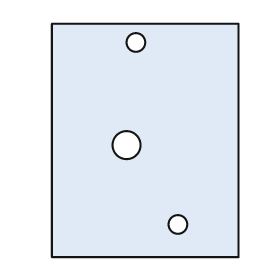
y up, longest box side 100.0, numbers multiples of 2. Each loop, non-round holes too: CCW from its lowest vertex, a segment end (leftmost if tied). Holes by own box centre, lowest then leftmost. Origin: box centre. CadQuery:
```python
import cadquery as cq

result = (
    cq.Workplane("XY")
    .moveTo(-40.0, -50.0)
    .lineTo(40.0, -50.0)
    .lineTo(40.0, 50.0)
    .lineTo(-40.0, 50.0)
    .close()
    .moveTo(14.0, -36.0)
    .circle(4.0)
    .moveTo(-8.0, -2.0)
    .circle(6.0)
    .moveTo(-4.0, 42.0)
    .circle(4.0)
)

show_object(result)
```